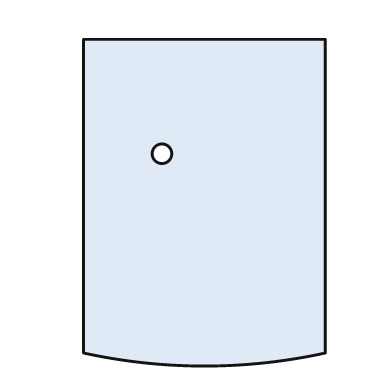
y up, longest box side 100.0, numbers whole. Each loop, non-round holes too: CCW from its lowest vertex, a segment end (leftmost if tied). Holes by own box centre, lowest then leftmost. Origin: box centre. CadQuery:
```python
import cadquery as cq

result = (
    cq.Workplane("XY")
    .moveTo(-37.0, -46.0)
    .threePointArc((0.0, -50.0), (37.0, -46.0))
    .lineTo(37.0, 50.0)
    .lineTo(-37.0, 50.0)
    .close()
    .moveTo(-13.0, 15.0)
    .circle(3.0)
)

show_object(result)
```